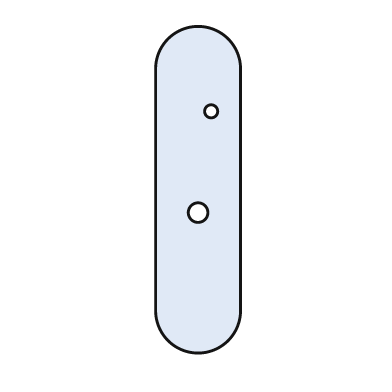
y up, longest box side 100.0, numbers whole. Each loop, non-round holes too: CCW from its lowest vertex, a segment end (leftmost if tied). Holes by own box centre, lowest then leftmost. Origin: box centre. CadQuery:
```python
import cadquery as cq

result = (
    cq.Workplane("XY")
    .moveTo(-13.0, -37.0)
    .threePointArc((0.0, -50.0), (13.0, -37.0))
    .lineTo(13.0, 37.0)
    .threePointArc((0.0, 50.0), (-13.0, 37.0))
    .close()
    .moveTo(0.0, -7.0)
    .circle(3.0)
    .moveTo(4.0, 24.0)
    .circle(2.0)
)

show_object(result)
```